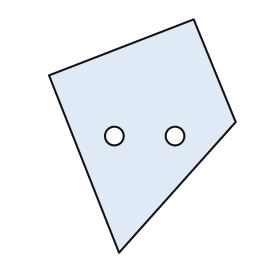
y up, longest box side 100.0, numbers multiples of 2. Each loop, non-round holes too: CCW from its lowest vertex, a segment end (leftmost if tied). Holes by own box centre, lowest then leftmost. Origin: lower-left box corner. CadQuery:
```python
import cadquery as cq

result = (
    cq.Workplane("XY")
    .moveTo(30.0, 0.0)
    .lineTo(80.0, 56.0)
    .lineTo(62.0, 100.0)
    .lineTo(0.0, 76.0)
    .close()
    .moveTo(28.0, 50.0)
    .circle(4.0)
    .moveTo(54.0, 50.0)
    .circle(4.0)
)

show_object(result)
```